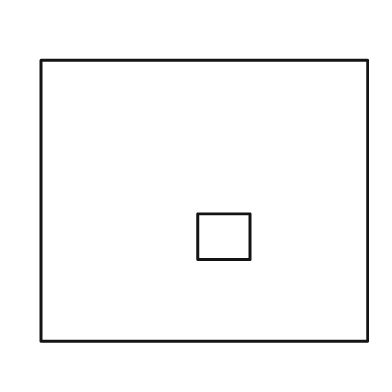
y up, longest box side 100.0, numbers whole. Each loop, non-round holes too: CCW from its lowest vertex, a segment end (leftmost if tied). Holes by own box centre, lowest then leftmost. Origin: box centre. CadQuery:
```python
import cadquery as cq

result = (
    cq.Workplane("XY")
    .moveTo(-50.0, -43.0)
    .lineTo(50.0, -43.0)
    .lineTo(50.0, 43.0)
    .lineTo(-50.0, 43.0)
    .close()
    .moveTo(-2.0, -18.0)
    .lineTo(14.0, -18.0)
    .lineTo(14.0, -4.0)
    .lineTo(-2.0, -4.0)
    .close()
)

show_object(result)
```